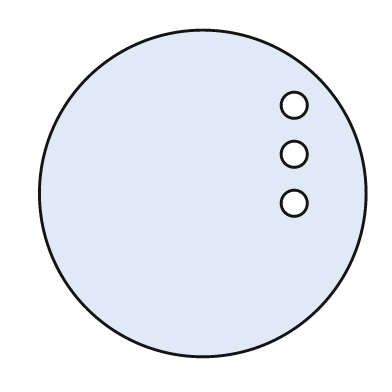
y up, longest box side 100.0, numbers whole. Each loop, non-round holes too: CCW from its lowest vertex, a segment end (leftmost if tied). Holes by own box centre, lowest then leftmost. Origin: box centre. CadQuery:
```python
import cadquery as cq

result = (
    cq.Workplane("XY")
    .moveTo(0.0, 0.0)
    .circle(50.0)
    .moveTo(28.0, -3.0)
    .circle(4.0)
    .moveTo(28.0, 12.0)
    .circle(4.0)
    .moveTo(28.0, 27.0)
    .circle(4.0)
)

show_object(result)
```